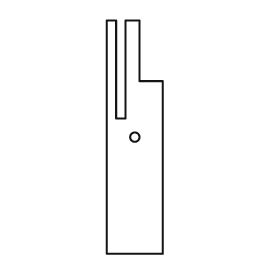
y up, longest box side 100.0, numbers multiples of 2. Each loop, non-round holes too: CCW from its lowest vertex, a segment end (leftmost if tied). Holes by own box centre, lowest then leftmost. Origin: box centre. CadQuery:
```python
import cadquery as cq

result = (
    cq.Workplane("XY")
    .moveTo(-12.0, -50.0)
    .lineTo(12.0, -50.0)
    .lineTo(12.0, 24.0)
    .lineTo(2.0, 24.0)
    .lineTo(2.0, 50.0)
    .lineTo(-4.0, 50.0)
    .lineTo(-4.0, 8.0)
    .lineTo(-8.0, 8.0)
    .lineTo(-8.0, 50.0)
    .lineTo(-12.0, 50.0)
    .close()
    .moveTo(0.0, 0.0)
    .circle(2.0)
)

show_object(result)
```